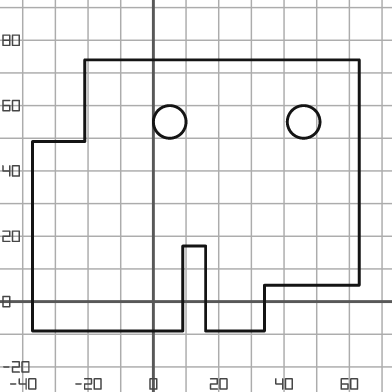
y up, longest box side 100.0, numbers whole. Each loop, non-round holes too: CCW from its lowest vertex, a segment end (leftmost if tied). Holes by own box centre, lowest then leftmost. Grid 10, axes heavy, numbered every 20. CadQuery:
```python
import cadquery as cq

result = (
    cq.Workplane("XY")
    .moveTo(-37.0, -9.0)
    .lineTo(9.0, -9.0)
    .lineTo(9.0, 17.0)
    .lineTo(16.0, 17.0)
    .lineTo(16.0, -9.0)
    .lineTo(34.0, -9.0)
    .lineTo(34.0, 5.0)
    .lineTo(63.0, 5.0)
    .lineTo(63.0, 74.0)
    .lineTo(-21.0, 74.0)
    .lineTo(-21.0, 49.0)
    .lineTo(-37.0, 49.0)
    .close()
    .moveTo(5.0, 55.0)
    .circle(5.0)
    .moveTo(46.0, 55.0)
    .circle(5.0)
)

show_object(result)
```